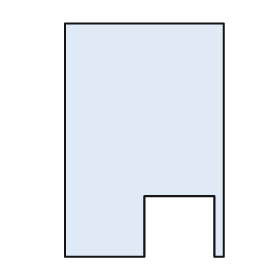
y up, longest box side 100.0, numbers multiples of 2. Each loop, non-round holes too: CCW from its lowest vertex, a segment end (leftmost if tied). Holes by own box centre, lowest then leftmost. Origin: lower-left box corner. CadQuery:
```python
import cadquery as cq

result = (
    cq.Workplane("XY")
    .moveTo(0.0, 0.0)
    .lineTo(34.0, 0.0)
    .lineTo(34.0, 26.0)
    .lineTo(64.0, 26.0)
    .lineTo(64.0, 0.0)
    .lineTo(68.0, 0.0)
    .lineTo(68.0, 100.0)
    .lineTo(0.0, 100.0)
    .close()
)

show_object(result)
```